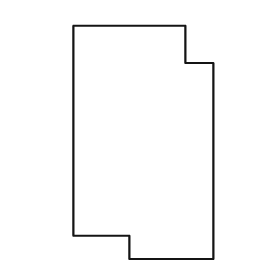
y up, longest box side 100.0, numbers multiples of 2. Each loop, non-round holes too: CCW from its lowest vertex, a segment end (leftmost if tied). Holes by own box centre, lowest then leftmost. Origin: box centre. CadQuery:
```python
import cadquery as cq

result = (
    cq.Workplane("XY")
    .moveTo(-6.0, -50.0)
    .lineTo(30.0, -50.0)
    .lineTo(30.0, 34.0)
    .lineTo(18.0, 34.0)
    .lineTo(18.0, 50.0)
    .lineTo(-30.0, 50.0)
    .lineTo(-30.0, -40.0)
    .lineTo(-6.0, -40.0)
    .close()
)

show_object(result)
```